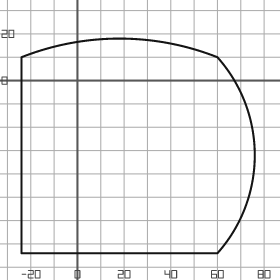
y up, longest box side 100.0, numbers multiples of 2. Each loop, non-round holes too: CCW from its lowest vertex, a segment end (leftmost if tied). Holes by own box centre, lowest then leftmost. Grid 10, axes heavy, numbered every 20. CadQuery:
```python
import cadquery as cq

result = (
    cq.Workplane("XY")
    .moveTo(-24.0, -74.0)
    .lineTo(60.0, -74.0)
    .threePointArc((76.0, -32.0), (60.0, 10.0))
    .threePointArc((18.0, 18.0), (-24.0, 10.0))
    .close()
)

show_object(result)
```